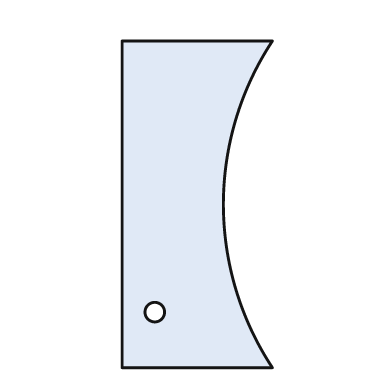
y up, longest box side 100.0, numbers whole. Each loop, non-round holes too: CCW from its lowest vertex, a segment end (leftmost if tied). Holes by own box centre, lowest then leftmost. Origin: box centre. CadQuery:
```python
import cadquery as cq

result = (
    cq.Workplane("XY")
    .moveTo(-23.0, -50.0)
    .lineTo(23.0, -50.0)
    .threePointArc((8.0, 0.0), (23.0, 50.0))
    .lineTo(-23.0, 50.0)
    .close()
    .moveTo(-13.0, -33.0)
    .circle(3.0)
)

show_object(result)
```